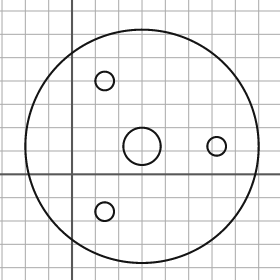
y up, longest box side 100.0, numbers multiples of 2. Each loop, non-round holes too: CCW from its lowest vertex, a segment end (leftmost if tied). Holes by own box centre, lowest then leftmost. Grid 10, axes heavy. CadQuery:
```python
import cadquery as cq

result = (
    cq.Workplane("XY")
    .moveTo(30.0, 12.0)
    .circle(50.0)
    .moveTo(14.0, -16.0)
    .circle(4.0)
    .moveTo(30.0, 12.0)
    .circle(8.0)
    .moveTo(62.0, 12.0)
    .circle(4.0)
    .moveTo(14.0, 40.0)
    .circle(4.0)
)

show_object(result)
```